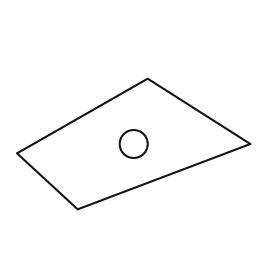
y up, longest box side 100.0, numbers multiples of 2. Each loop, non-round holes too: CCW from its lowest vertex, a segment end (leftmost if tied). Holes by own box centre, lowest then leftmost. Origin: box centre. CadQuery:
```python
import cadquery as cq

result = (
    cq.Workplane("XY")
    .moveTo(-24.0, -28.0)
    .lineTo(50.0, 0.0)
    .lineTo(6.0, 28.0)
    .lineTo(-50.0, -4.0)
    .close()
    .moveTo(0.0, 0.0)
    .circle(6.0)
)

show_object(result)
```